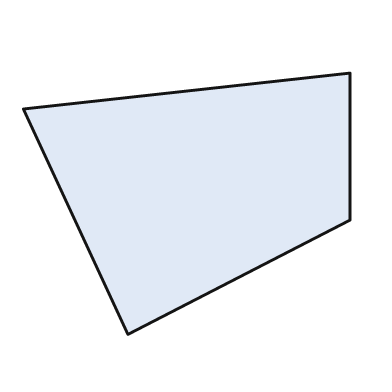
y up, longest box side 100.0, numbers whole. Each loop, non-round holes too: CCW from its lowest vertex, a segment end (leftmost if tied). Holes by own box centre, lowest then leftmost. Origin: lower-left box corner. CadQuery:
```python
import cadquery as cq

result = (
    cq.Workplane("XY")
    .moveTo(32.0, 0.0)
    .lineTo(100.0, 35.0)
    .lineTo(100.0, 80.0)
    .lineTo(0.0, 69.0)
    .close()
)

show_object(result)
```